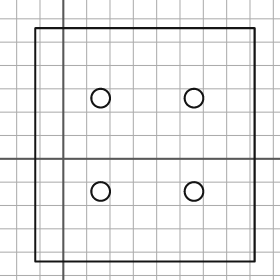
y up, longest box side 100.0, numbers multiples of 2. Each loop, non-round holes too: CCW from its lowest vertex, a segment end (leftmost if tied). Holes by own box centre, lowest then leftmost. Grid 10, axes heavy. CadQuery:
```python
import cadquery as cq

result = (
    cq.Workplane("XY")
    .moveTo(-12.0, -44.0)
    .lineTo(82.0, -44.0)
    .lineTo(82.0, 56.0)
    .lineTo(-12.0, 56.0)
    .close()
    .moveTo(16.0, -14.0)
    .circle(4.0)
    .moveTo(56.0, -14.0)
    .circle(4.0)
    .moveTo(16.0, 26.0)
    .circle(4.0)
    .moveTo(56.0, 26.0)
    .circle(4.0)
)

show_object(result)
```